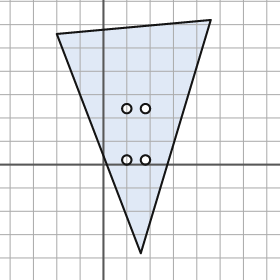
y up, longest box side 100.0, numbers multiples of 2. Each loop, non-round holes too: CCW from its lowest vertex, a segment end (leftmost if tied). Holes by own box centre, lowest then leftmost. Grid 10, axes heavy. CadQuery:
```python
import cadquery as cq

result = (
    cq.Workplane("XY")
    .moveTo(16.0, -38.0)
    .lineTo(46.0, 62.0)
    .lineTo(-20.0, 56.0)
    .close()
    .moveTo(10.0, 2.0)
    .circle(2.0)
    .moveTo(18.0, 2.0)
    .circle(2.0)
    .moveTo(10.0, 24.0)
    .circle(2.0)
    .moveTo(18.0, 24.0)
    .circle(2.0)
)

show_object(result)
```